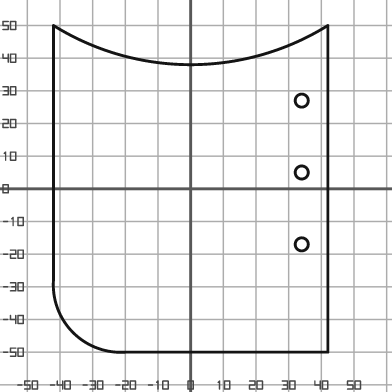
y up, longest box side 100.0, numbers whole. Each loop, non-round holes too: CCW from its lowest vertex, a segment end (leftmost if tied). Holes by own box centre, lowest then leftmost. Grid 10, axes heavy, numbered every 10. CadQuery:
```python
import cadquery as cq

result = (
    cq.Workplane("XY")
    .moveTo(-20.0, -50.0)
    .lineTo(42.0, -50.0)
    .lineTo(42.0, 50.0)
    .threePointArc((0.0, 38.0), (-42.0, 50.0))
    .lineTo(-42.0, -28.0)
    .threePointArc((-36.0, -44.0), (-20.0, -50.0))
    .close()
    .moveTo(34.0, -17.0)
    .circle(2.0)
    .moveTo(34.0, 5.0)
    .circle(2.0)
    .moveTo(34.0, 27.0)
    .circle(2.0)
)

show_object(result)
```